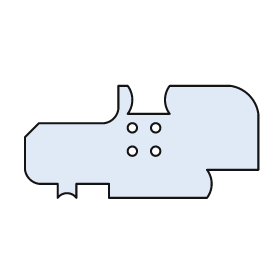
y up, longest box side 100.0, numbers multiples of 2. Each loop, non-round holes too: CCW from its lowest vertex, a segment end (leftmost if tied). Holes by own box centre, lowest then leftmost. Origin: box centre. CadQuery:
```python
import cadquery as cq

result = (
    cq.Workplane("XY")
    .moveTo(-36.0, -24.0)
    .threePointArc((-32.0, -22.0), (-28.0, -24.0))
    .lineTo(-28.0, -18.0)
    .lineTo(-14.0, -18.0)
    .lineTo(-14.0, -24.0)
    .lineTo(28.0, -24.0)
    .threePointArc((30.0, -18.0), (28.0, -12.0))
    .lineTo(50.0, -12.0)
    .lineTo(50.0, 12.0)
    .threePointArc((46.0, 20.0), (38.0, 24.0))
    .lineTo(12.0, 24.0)
    .threePointArc((10.0, 18.0), (12.0, 12.0))
    .lineTo(-6.0, 12.0)
    .threePointArc((-4.0, 18.0), (-6.0, 24.0))
    .lineTo(-10.0, 24.0)
    .lineTo(-10.0, 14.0)
    .threePointArc((-12.0, 10.0), (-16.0, 8.0))
    .lineTo(-44.0, 8.0)
    .lineTo(-50.0, 2.0)
    .lineTo(-50.0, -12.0)
    .threePointArc((-48.0, -16.0), (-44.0, -18.0))
    .lineTo(-36.0, -18.0)
    .close()
    .moveTo(-4.0, -4.0)
    .circle(2.0)
    .moveTo(6.0, -4.0)
    .circle(2.0)
    .moveTo(-4.0, 6.0)
    .circle(2.0)
    .moveTo(6.0, 6.0)
    .circle(2.0)
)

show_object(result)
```